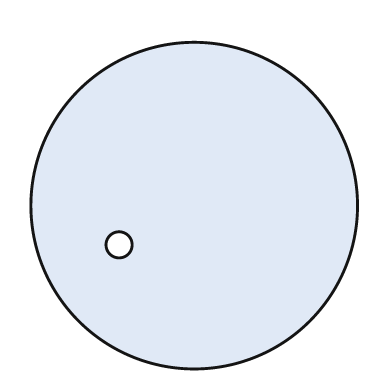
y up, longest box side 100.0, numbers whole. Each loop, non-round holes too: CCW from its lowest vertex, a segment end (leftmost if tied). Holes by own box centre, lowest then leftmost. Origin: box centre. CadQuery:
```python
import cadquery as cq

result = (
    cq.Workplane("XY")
    .moveTo(0.0, 0.0)
    .circle(50.0)
    .moveTo(-23.0, -12.0)
    .circle(4.0)
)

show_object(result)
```